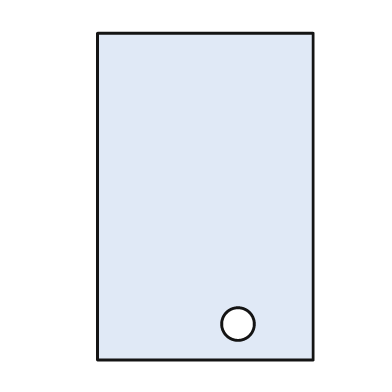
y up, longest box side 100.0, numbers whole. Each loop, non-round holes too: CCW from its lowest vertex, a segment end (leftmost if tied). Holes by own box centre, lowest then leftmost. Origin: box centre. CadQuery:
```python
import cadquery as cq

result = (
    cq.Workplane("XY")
    .moveTo(-33.0, -50.0)
    .lineTo(33.0, -50.0)
    .lineTo(33.0, 50.0)
    .lineTo(-33.0, 50.0)
    .close()
    .moveTo(10.0, -39.0)
    .circle(5.0)
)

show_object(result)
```